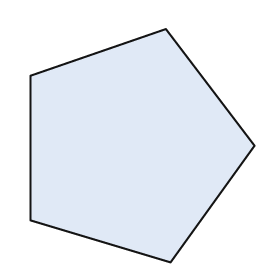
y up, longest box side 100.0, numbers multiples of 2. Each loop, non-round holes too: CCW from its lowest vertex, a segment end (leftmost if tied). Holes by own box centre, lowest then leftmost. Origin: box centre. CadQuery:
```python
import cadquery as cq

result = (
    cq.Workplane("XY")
    .moveTo(12.0, -50.0)
    .lineTo(48.0, 0.0)
    .lineTo(10.0, 50.0)
    .lineTo(-48.0, 30.0)
    .lineTo(-48.0, -32.0)
    .close()
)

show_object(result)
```